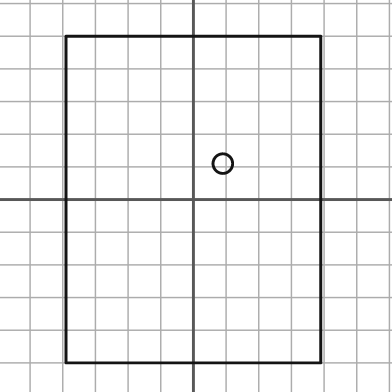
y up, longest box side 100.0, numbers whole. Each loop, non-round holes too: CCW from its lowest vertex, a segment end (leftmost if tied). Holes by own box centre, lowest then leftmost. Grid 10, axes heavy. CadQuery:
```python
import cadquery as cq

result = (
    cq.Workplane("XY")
    .moveTo(-39.0, -50.0)
    .lineTo(39.0, -50.0)
    .lineTo(39.0, 50.0)
    .lineTo(-39.0, 50.0)
    .close()
    .moveTo(9.0, 11.0)
    .circle(3.0)
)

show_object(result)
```